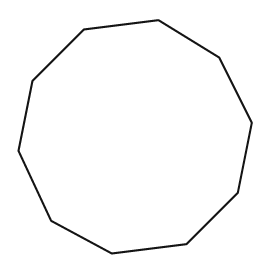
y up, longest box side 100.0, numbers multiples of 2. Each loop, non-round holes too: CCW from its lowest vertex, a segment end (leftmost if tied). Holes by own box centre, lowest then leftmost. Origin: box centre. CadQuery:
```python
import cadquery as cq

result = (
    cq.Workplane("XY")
    .moveTo(-10.0, -50.0)
    .lineTo(22.0, -46.0)
    .lineTo(44.0, -24.0)
    .lineTo(50.0, 6.0)
    .lineTo(36.0, 34.0)
    .lineTo(10.0, 50.0)
    .lineTo(-22.0, 46.0)
    .lineTo(-44.0, 24.0)
    .lineTo(-50.0, -6.0)
    .lineTo(-36.0, -36.0)
    .close()
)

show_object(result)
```